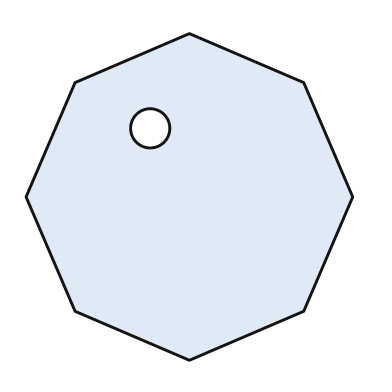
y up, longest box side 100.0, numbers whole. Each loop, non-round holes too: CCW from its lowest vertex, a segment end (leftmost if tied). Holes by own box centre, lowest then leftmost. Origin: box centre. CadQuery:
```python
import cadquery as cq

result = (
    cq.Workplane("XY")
    .moveTo(0.0, -50.0)
    .lineTo(35.0, -35.0)
    .lineTo(50.0, 0.0)
    .lineTo(35.0, 35.0)
    .lineTo(0.0, 50.0)
    .lineTo(-35.0, 35.0)
    .lineTo(-50.0, 0.0)
    .lineTo(-35.0, -35.0)
    .close()
    .moveTo(-12.0, 21.0)
    .circle(6.0)
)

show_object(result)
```